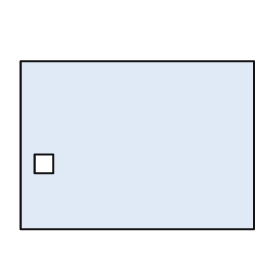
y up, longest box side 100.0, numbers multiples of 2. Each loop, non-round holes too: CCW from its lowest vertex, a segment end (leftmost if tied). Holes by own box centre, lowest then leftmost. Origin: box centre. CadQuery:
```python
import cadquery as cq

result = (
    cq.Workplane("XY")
    .moveTo(-50.0, -36.0)
    .lineTo(50.0, -36.0)
    .lineTo(50.0, 36.0)
    .lineTo(-50.0, 36.0)
    .close()
    .moveTo(-44.0, -12.0)
    .lineTo(-36.0, -12.0)
    .lineTo(-36.0, -4.0)
    .lineTo(-44.0, -4.0)
    .close()
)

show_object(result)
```